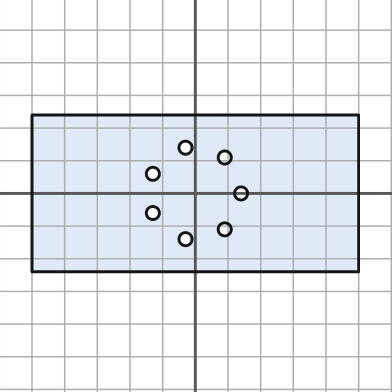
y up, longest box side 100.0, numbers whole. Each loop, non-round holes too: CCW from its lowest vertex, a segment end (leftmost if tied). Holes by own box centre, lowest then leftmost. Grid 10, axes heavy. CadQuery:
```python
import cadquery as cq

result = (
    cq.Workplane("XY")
    .moveTo(-50.0, -24.0)
    .lineTo(50.0, -24.0)
    .lineTo(50.0, 24.0)
    .lineTo(-50.0, 24.0)
    .close()
    .moveTo(-3.0, -14.0)
    .circle(2.0)
    .moveTo(9.0, -11.0)
    .circle(2.0)
    .moveTo(-13.0, -6.0)
    .circle(2.0)
    .moveTo(14.0, 0.0)
    .circle(2.0)
    .moveTo(-13.0, 6.0)
    .circle(2.0)
    .moveTo(9.0, 11.0)
    .circle(2.0)
    .moveTo(-3.0, 14.0)
    .circle(2.0)
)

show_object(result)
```